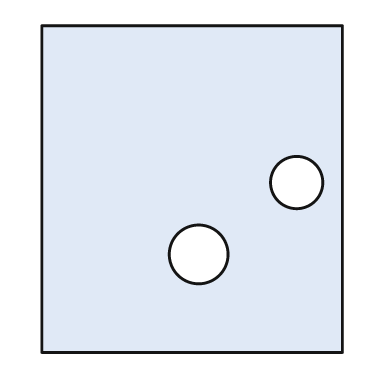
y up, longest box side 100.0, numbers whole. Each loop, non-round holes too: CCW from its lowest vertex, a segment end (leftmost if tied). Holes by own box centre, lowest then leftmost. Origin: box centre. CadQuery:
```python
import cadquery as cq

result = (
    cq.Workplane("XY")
    .moveTo(-46.0, -50.0)
    .lineTo(46.0, -50.0)
    .lineTo(46.0, 50.0)
    .lineTo(-46.0, 50.0)
    .close()
    .moveTo(2.0, -20.0)
    .circle(9.0)
    .moveTo(32.0, 2.0)
    .circle(8.0)
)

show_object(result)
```